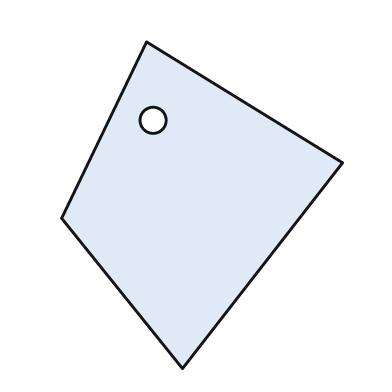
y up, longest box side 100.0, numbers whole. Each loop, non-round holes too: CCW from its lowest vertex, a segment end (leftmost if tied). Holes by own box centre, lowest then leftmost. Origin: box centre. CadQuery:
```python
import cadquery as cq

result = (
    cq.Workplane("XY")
    .moveTo(-6.0, -50.0)
    .lineTo(43.0, 13.0)
    .lineTo(-17.0, 50.0)
    .lineTo(-43.0, -4.0)
    .close()
    .moveTo(-15.0, 26.0)
    .circle(4.0)
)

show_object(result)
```